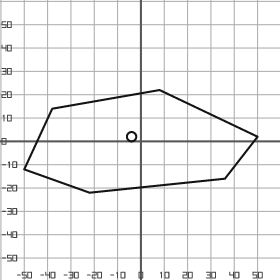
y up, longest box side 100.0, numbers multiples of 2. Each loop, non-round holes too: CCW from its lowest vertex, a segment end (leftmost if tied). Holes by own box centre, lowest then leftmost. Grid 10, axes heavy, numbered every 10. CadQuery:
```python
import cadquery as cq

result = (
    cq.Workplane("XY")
    .moveTo(-22.0, -22.0)
    .lineTo(36.0, -16.0)
    .lineTo(50.0, 2.0)
    .lineTo(8.0, 22.0)
    .lineTo(-38.0, 14.0)
    .lineTo(-50.0, -12.0)
    .close()
    .moveTo(-4.0, 2.0)
    .circle(2.0)
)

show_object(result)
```